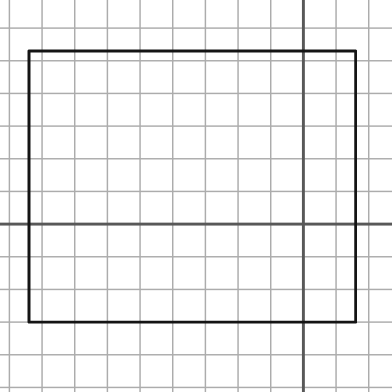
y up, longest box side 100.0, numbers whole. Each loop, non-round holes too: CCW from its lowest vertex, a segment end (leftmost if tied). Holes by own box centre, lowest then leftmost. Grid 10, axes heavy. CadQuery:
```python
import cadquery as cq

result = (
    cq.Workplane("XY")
    .moveTo(-84.0, -30.0)
    .lineTo(16.0, -30.0)
    .lineTo(16.0, 53.0)
    .lineTo(-84.0, 53.0)
    .close()
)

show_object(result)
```